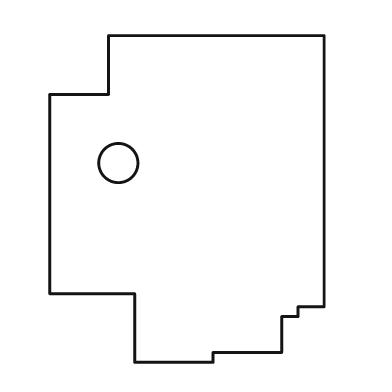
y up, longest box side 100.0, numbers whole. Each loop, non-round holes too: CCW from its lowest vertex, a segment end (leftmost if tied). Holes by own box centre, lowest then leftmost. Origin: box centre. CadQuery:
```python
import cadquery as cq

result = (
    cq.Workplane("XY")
    .moveTo(-16.0, -50.0)
    .lineTo(8.0, -50.0)
    .lineTo(8.0, -47.0)
    .lineTo(29.0, -47.0)
    .lineTo(29.0, -36.0)
    .lineTo(34.0, -36.0)
    .lineTo(34.0, -33.0)
    .lineTo(42.0, -33.0)
    .lineTo(42.0, 50.0)
    .lineTo(-24.0, 50.0)
    .lineTo(-24.0, 32.0)
    .lineTo(-42.0, 32.0)
    .lineTo(-42.0, -29.0)
    .lineTo(-16.0, -29.0)
    .close()
    .moveTo(-21.0, 11.0)
    .circle(6.0)
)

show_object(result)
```